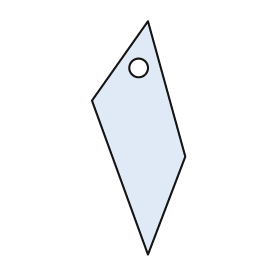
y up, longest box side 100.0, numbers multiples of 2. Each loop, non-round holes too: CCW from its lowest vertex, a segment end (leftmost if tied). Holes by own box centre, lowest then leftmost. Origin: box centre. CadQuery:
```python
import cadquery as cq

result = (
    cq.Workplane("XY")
    .moveTo(4.0, -50.0)
    .lineTo(20.0, -8.0)
    .lineTo(4.0, 50.0)
    .lineTo(-20.0, 16.0)
    .close()
    .moveTo(0.0, 30.0)
    .circle(4.0)
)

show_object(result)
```